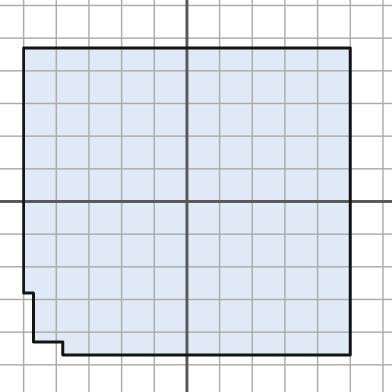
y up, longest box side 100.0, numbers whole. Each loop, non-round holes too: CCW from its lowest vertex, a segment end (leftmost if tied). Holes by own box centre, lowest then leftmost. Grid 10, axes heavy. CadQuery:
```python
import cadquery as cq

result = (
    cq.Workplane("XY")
    .moveTo(-38.0, -47.0)
    .lineTo(50.0, -47.0)
    .lineTo(50.0, 47.0)
    .lineTo(-50.0, 47.0)
    .lineTo(-50.0, -28.0)
    .lineTo(-47.0, -28.0)
    .lineTo(-47.0, -43.0)
    .lineTo(-38.0, -43.0)
    .close()
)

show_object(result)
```